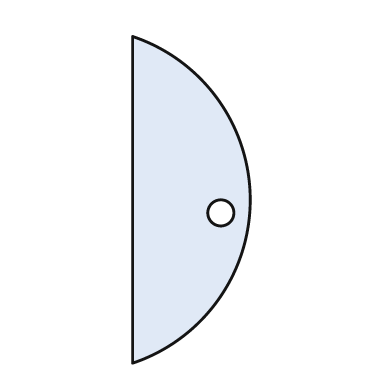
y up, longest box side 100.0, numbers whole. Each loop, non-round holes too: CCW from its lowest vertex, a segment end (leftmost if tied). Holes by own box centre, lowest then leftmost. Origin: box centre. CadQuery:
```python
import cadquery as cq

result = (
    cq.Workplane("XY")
    .moveTo(-18.0, -50.0)
    .threePointArc((18.0, 0.0), (-18.0, 50.0))
    .close()
    .moveTo(9.0, -4.0)
    .circle(4.0)
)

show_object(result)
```